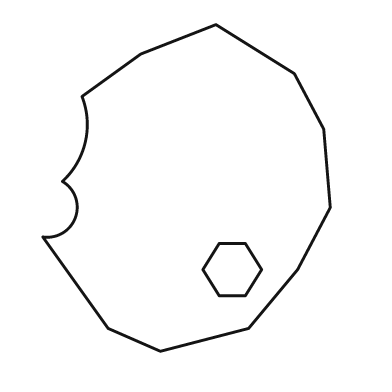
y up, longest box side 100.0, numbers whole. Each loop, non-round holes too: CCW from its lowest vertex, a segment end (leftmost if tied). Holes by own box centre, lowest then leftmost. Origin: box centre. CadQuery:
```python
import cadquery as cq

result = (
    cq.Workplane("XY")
    .moveTo(-8.0, -50.0)
    .lineTo(19.0, -43.0)
    .lineTo(34.0, -25.0)
    .lineTo(44.0, -6.0)
    .lineTo(42.0, 18.0)
    .lineTo(33.0, 35.0)
    .lineTo(9.0, 50.0)
    .lineTo(-14.0, 41.0)
    .lineTo(-32.0, 28.0)
    .threePointArc((-31.0, 14.0), (-38.0, 2.0))
    .threePointArc((-34.0, -9.0), (-44.0, -15.0))
    .lineTo(-24.0, -43.0)
    .close()
    .moveTo(10.0, -33.0)
    .lineTo(18.0, -33.0)
    .lineTo(23.0, -25.0)
    .lineTo(18.0, -17.0)
    .lineTo(10.0, -17.0)
    .lineTo(5.0, -25.0)
    .close()
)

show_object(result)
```